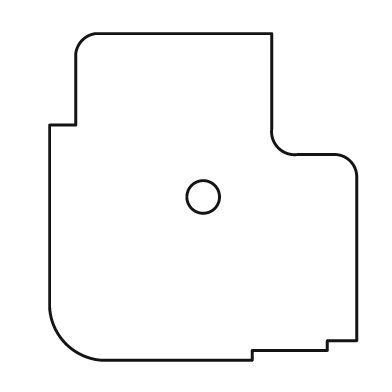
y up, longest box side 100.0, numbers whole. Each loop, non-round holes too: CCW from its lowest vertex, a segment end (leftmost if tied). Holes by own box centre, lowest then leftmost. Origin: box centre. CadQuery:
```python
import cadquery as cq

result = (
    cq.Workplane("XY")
    .moveTo(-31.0, -50.0)
    .lineTo(15.0, -50.0)
    .lineTo(15.0, -47.0)
    .lineTo(38.0, -47.0)
    .lineTo(38.0, -44.0)
    .lineTo(47.0, -44.0)
    .lineTo(47.0, 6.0)
    .threePointArc((45.0, 11.0), (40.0, 13.0))
    .lineTo(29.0, 13.0)
    .threePointArc((23.0, 15.0), (21.0, 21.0))
    .lineTo(21.0, 50.0)
    .lineTo(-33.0, 50.0)
    .threePointArc((-37.0, 48.0), (-39.0, 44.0))
    .lineTo(-39.0, 22.0)
    .lineTo(-47.0, 22.0)
    .lineTo(-47.0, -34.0)
    .threePointArc((-42.0, -45.0), (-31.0, -50.0))
    .close()
    .moveTo(0.0, 0.0)
    .circle(5.0)
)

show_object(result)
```